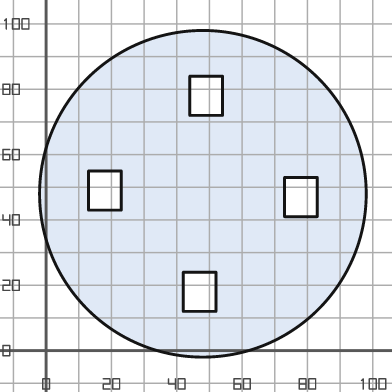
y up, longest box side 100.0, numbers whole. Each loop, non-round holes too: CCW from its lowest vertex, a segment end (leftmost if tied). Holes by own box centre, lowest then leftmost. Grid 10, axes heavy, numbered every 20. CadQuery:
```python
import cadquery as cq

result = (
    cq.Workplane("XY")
    .moveTo(48.0, 48.0)
    .circle(50.0)
    .moveTo(42.0, 12.0)
    .lineTo(52.0, 12.0)
    .lineTo(52.0, 24.0)
    .lineTo(42.0, 24.0)
    .close()
    .moveTo(73.0, 41.0)
    .lineTo(83.0, 41.0)
    .lineTo(83.0, 53.0)
    .lineTo(73.0, 53.0)
    .close()
    .moveTo(13.0, 43.0)
    .lineTo(23.0, 43.0)
    .lineTo(23.0, 55.0)
    .lineTo(13.0, 55.0)
    .close()
    .moveTo(44.0, 72.0)
    .lineTo(54.0, 72.0)
    .lineTo(54.0, 84.0)
    .lineTo(44.0, 84.0)
    .close()
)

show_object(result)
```